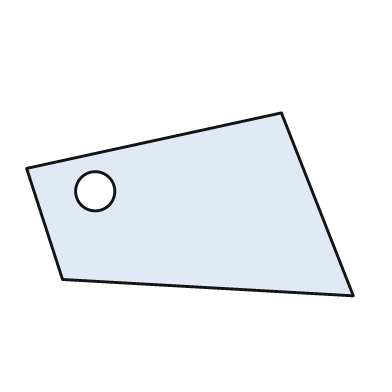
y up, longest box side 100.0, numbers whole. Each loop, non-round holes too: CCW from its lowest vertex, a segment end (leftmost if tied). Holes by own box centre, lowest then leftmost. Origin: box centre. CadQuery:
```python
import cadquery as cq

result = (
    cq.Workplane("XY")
    .moveTo(50.0, -28.0)
    .lineTo(28.0, 28.0)
    .lineTo(-50.0, 11.0)
    .lineTo(-39.0, -23.0)
    .close()
    .moveTo(-29.0, 4.0)
    .circle(6.0)
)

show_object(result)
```